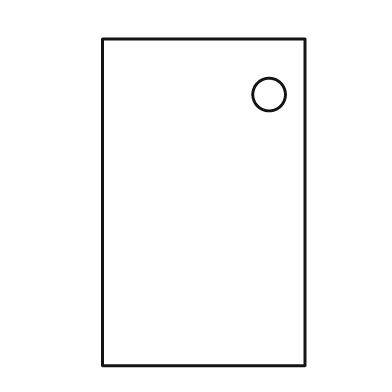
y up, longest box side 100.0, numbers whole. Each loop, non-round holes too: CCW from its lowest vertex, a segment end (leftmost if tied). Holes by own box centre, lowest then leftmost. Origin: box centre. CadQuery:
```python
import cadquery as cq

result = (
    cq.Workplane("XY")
    .moveTo(-31.0, -50.0)
    .lineTo(31.0, -50.0)
    .lineTo(31.0, 50.0)
    .lineTo(-31.0, 50.0)
    .close()
    .moveTo(20.0, 33.0)
    .circle(5.0)
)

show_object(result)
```